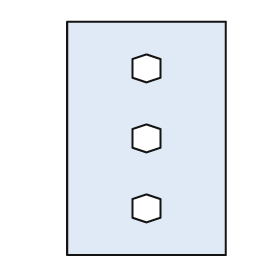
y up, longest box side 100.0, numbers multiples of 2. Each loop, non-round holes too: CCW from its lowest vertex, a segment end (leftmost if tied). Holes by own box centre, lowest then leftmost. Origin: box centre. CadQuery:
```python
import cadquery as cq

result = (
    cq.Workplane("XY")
    .moveTo(-34.0, -50.0)
    .lineTo(34.0, -50.0)
    .lineTo(34.0, 50.0)
    .lineTo(-34.0, 50.0)
    .close()
    .moveTo(0.0, -36.0)
    .lineTo(6.0, -34.0)
    .lineTo(6.0, -26.0)
    .lineTo(0.0, -24.0)
    .lineTo(-6.0, -26.0)
    .lineTo(-6.0, -34.0)
    .close()
    .moveTo(0.0, -6.0)
    .lineTo(6.0, -4.0)
    .lineTo(6.0, 4.0)
    .lineTo(0.0, 6.0)
    .lineTo(-6.0, 4.0)
    .lineTo(-6.0, -4.0)
    .close()
    .moveTo(0.0, 24.0)
    .lineTo(6.0, 26.0)
    .lineTo(6.0, 34.0)
    .lineTo(0.0, 36.0)
    .lineTo(-6.0, 34.0)
    .lineTo(-6.0, 26.0)
    .close()
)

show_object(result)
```